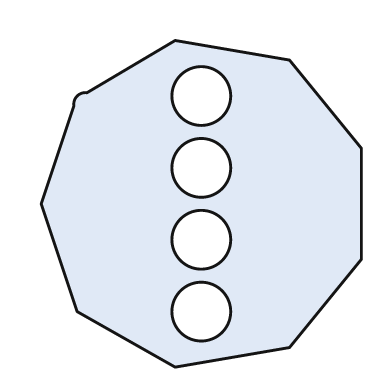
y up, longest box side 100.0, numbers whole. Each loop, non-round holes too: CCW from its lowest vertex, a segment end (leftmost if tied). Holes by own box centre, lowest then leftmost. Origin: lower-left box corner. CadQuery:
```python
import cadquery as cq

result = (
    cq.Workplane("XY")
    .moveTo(41.0, 0.0)
    .lineTo(76.0, 6.0)
    .lineTo(98.0, 33.0)
    .lineTo(98.0, 67.0)
    .lineTo(76.0, 94.0)
    .lineTo(41.0, 100.0)
    .lineTo(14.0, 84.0)
    .threePointArc((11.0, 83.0), (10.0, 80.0))
    .lineTo(0.0, 50.0)
    .lineTo(11.0, 17.0)
    .close()
    .moveTo(49.0, 17.0)
    .circle(9.0)
    .moveTo(49.0, 39.0)
    .circle(9.0)
    .moveTo(49.0, 61.0)
    .circle(9.0)
    .moveTo(49.0, 83.0)
    .circle(9.0)
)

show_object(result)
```